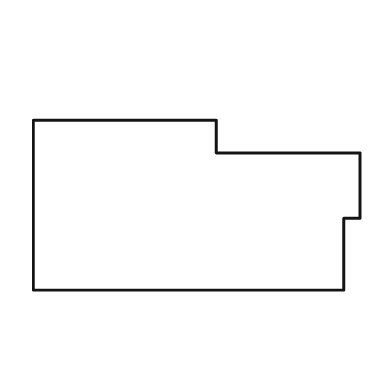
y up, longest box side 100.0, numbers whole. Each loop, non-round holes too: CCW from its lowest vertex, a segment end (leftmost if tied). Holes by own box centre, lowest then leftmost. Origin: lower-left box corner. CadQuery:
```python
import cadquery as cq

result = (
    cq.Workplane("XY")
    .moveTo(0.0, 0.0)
    .lineTo(95.0, 0.0)
    .lineTo(95.0, 22.0)
    .lineTo(100.0, 22.0)
    .lineTo(100.0, 42.0)
    .lineTo(56.0, 42.0)
    .lineTo(56.0, 52.0)
    .lineTo(0.0, 52.0)
    .close()
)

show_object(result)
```